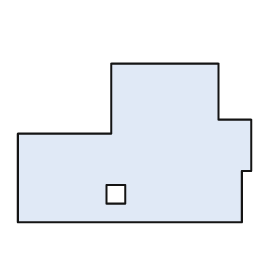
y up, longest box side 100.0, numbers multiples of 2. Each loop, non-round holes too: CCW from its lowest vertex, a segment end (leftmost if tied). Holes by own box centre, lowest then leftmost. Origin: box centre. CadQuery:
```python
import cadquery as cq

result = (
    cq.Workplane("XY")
    .moveTo(-50.0, -34.0)
    .lineTo(46.0, -34.0)
    .lineTo(46.0, -12.0)
    .lineTo(50.0, -12.0)
    .lineTo(50.0, 10.0)
    .lineTo(36.0, 10.0)
    .lineTo(36.0, 34.0)
    .lineTo(-10.0, 34.0)
    .lineTo(-10.0, 4.0)
    .lineTo(-50.0, 4.0)
    .close()
    .moveTo(-12.0, -26.0)
    .lineTo(-4.0, -26.0)
    .lineTo(-4.0, -18.0)
    .lineTo(-12.0, -18.0)
    .close()
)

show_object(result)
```